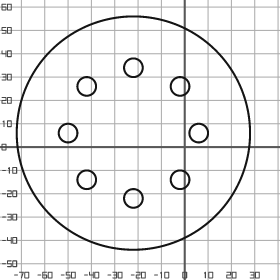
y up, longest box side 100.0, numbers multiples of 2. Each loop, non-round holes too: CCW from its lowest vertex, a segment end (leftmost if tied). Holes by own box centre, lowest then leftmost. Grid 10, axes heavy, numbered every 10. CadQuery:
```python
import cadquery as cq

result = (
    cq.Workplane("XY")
    .moveTo(-22.0, 6.0)
    .circle(50.0)
    .moveTo(-22.0, -22.0)
    .circle(4.0)
    .moveTo(-42.0, -14.0)
    .circle(4.0)
    .moveTo(-2.0, -14.0)
    .circle(4.0)
    .moveTo(-50.0, 6.0)
    .circle(4.0)
    .moveTo(6.0, 6.0)
    .circle(4.0)
    .moveTo(-42.0, 26.0)
    .circle(4.0)
    .moveTo(-2.0, 26.0)
    .circle(4.0)
    .moveTo(-22.0, 34.0)
    .circle(4.0)
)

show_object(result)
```